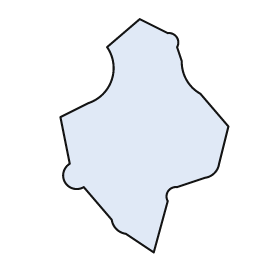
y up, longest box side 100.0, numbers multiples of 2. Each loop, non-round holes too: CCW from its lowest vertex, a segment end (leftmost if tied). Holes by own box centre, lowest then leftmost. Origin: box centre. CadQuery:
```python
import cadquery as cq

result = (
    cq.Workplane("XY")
    .moveTo(4.0, -50.0)
    .lineTo(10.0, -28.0)
    .threePointArc((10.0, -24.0), (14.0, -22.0))
    .lineTo(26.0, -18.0)
    .threePointArc((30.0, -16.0), (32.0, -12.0))
    .lineTo(36.0, 4.0)
    .lineTo(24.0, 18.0)
    .threePointArc((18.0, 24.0), (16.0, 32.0))
    .lineTo(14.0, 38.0)
    .threePointArc((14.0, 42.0), (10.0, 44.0))
    .lineTo(-2.0, 50.0)
    .lineTo(-16.0, 38.0)
    .threePointArc((-14.0, 24.0), (-24.0, 14.0))
    .lineTo(-36.0, 8.0)
    .lineTo(-32.0, -12.0)
    .threePointArc((-34.0, -20.0), (-26.0, -22.0))
    .lineTo(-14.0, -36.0)
    .threePointArc((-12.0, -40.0), (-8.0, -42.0))
    .close()
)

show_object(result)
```